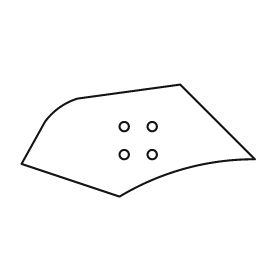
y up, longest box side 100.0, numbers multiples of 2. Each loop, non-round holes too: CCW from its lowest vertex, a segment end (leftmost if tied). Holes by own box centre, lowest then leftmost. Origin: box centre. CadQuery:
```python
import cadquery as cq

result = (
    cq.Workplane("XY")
    .moveTo(-8.0, -24.0)
    .threePointArc((20.0, -12.0), (50.0, -8.0))
    .lineTo(18.0, 24.0)
    .lineTo(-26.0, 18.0)
    .threePointArc((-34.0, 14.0), (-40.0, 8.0))
    .lineTo(-50.0, -10.0)
    .close()
    .moveTo(-6.0, -6.0)
    .circle(2.0)
    .moveTo(6.0, -6.0)
    .circle(2.0)
    .moveTo(-6.0, 6.0)
    .circle(2.0)
    .moveTo(6.0, 6.0)
    .circle(2.0)
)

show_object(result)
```